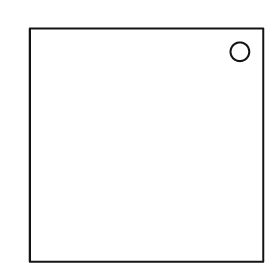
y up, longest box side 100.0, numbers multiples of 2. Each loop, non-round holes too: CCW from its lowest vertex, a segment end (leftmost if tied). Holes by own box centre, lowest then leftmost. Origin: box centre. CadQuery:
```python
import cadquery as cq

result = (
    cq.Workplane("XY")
    .moveTo(-50.0, -50.0)
    .lineTo(50.0, -50.0)
    .lineTo(50.0, 50.0)
    .lineTo(-50.0, 50.0)
    .close()
    .moveTo(40.0, 40.0)
    .circle(4.0)
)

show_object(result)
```